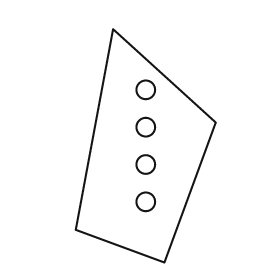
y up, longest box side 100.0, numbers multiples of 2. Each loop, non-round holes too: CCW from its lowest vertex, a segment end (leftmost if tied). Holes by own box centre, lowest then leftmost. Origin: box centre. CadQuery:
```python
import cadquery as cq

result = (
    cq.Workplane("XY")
    .moveTo(8.0, -50.0)
    .lineTo(30.0, 10.0)
    .lineTo(-14.0, 50.0)
    .lineTo(-30.0, -36.0)
    .close()
    .moveTo(0.0, -24.0)
    .circle(4.0)
    .moveTo(0.0, -8.0)
    .circle(4.0)
    .moveTo(0.0, 8.0)
    .circle(4.0)
    .moveTo(0.0, 24.0)
    .circle(4.0)
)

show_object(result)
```